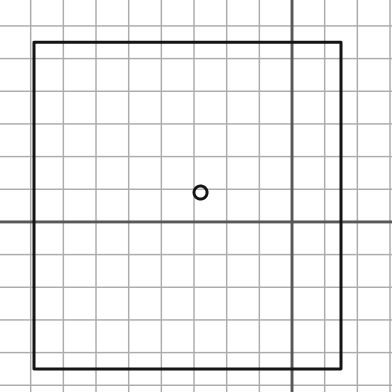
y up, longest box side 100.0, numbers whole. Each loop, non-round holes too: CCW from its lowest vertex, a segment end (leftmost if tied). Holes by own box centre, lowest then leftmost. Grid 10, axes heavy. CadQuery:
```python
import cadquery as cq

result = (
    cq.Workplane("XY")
    .moveTo(-79.0, -45.0)
    .lineTo(15.0, -45.0)
    .lineTo(15.0, 55.0)
    .lineTo(-79.0, 55.0)
    .close()
    .moveTo(-28.0, 9.0)
    .circle(2.0)
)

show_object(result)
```